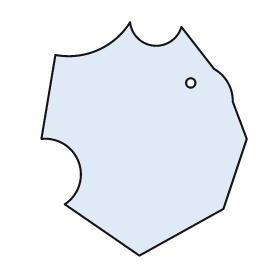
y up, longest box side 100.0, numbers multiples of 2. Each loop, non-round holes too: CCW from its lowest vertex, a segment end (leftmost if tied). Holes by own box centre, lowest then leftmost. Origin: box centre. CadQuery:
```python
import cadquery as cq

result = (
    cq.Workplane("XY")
    .moveTo(-2.0, -50.0)
    .lineTo(34.0, -30.0)
    .lineTo(44.0, 0.0)
    .lineTo(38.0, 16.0)
    .threePointArc((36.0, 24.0), (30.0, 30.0))
    .lineTo(16.0, 48.0)
    .threePointArc((4.0, 40.0), (-6.0, 50.0))
    .threePointArc((-20.0, 38.0), (-38.0, 36.0))
    .lineTo(-44.0, 0.0)
    .threePointArc((-28.0, -10.0), (-34.0, -28.0))
    .close()
    .moveTo(20.0, 24.0)
    .circle(2.0)
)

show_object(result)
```